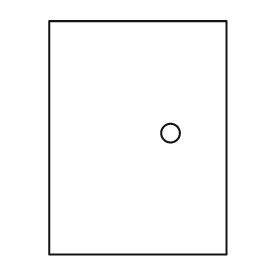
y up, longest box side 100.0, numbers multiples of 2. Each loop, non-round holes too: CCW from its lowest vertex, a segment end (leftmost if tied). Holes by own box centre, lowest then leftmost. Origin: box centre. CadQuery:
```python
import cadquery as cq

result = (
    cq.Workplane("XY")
    .moveTo(-38.0, -50.0)
    .lineTo(38.0, -50.0)
    .lineTo(38.0, 50.0)
    .lineTo(-38.0, 50.0)
    .close()
    .moveTo(14.0, 2.0)
    .circle(4.0)
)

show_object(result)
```